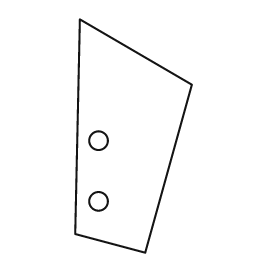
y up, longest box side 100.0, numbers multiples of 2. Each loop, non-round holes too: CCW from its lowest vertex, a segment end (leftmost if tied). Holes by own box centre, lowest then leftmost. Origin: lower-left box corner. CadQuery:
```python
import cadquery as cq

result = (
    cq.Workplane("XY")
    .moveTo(30.0, 0.0)
    .lineTo(50.0, 72.0)
    .lineTo(2.0, 100.0)
    .lineTo(0.0, 8.0)
    .close()
    .moveTo(10.0, 22.0)
    .circle(4.0)
    .moveTo(10.0, 48.0)
    .circle(4.0)
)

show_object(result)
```